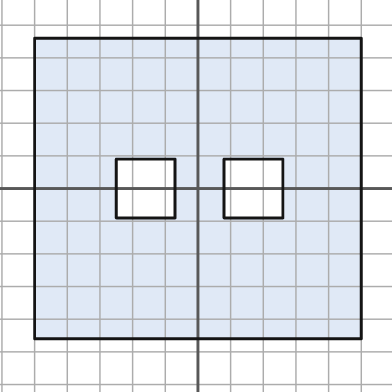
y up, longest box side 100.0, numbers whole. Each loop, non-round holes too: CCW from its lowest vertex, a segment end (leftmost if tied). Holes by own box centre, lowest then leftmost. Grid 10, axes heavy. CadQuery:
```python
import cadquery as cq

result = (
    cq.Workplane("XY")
    .moveTo(-50.0, -46.0)
    .lineTo(50.0, -46.0)
    .lineTo(50.0, 46.0)
    .lineTo(-50.0, 46.0)
    .close()
    .moveTo(-25.0, -9.0)
    .lineTo(-7.0, -9.0)
    .lineTo(-7.0, 9.0)
    .lineTo(-25.0, 9.0)
    .close()
    .moveTo(8.0, -9.0)
    .lineTo(26.0, -9.0)
    .lineTo(26.0, 9.0)
    .lineTo(8.0, 9.0)
    .close()
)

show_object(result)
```